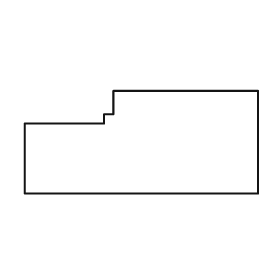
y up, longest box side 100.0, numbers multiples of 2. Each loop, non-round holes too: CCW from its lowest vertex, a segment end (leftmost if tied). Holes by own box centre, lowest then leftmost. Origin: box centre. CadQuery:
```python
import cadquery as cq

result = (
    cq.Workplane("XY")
    .moveTo(-50.0, -22.0)
    .lineTo(50.0, -22.0)
    .lineTo(50.0, 22.0)
    .lineTo(-12.0, 22.0)
    .lineTo(-12.0, 12.0)
    .lineTo(-16.0, 12.0)
    .lineTo(-16.0, 8.0)
    .lineTo(-50.0, 8.0)
    .close()
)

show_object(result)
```